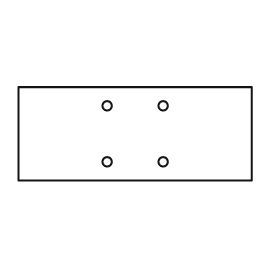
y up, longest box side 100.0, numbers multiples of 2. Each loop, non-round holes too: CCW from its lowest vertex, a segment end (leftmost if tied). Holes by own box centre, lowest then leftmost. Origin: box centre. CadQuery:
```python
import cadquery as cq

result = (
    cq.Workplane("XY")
    .moveTo(-50.0, -20.0)
    .lineTo(50.0, -20.0)
    .lineTo(50.0, 20.0)
    .lineTo(-50.0, 20.0)
    .close()
    .moveTo(-12.0, -12.0)
    .circle(2.0)
    .moveTo(12.0, -12.0)
    .circle(2.0)
    .moveTo(-12.0, 12.0)
    .circle(2.0)
    .moveTo(12.0, 12.0)
    .circle(2.0)
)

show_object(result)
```